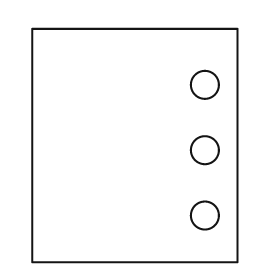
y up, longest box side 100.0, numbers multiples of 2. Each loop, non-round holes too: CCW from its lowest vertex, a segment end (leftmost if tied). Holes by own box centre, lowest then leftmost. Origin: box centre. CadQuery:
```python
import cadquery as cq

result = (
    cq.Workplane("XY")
    .moveTo(-44.0, -50.0)
    .lineTo(44.0, -50.0)
    .lineTo(44.0, 50.0)
    .lineTo(-44.0, 50.0)
    .close()
    .moveTo(30.0, -30.0)
    .circle(6.0)
    .moveTo(30.0, -2.0)
    .circle(6.0)
    .moveTo(30.0, 26.0)
    .circle(6.0)
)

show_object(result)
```